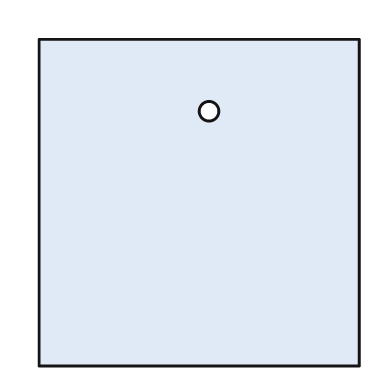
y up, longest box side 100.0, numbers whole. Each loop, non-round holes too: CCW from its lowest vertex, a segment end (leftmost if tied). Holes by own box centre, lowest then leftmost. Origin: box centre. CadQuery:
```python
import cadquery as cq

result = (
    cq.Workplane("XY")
    .moveTo(-49.0, -50.0)
    .lineTo(49.0, -50.0)
    .lineTo(49.0, 50.0)
    .lineTo(-49.0, 50.0)
    .close()
    .moveTo(3.0, 28.0)
    .circle(3.0)
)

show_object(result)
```